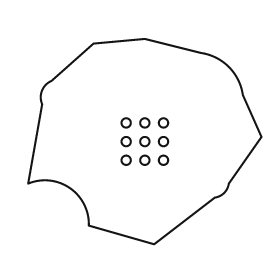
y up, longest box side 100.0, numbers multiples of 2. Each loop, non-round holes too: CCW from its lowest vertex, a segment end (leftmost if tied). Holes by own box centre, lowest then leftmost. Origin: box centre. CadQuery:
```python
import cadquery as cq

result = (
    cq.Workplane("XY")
    .moveTo(4.0, -44.0)
    .lineTo(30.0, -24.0)
    .threePointArc((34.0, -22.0), (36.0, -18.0))
    .lineTo(50.0, 2.0)
    .lineTo(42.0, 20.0)
    .threePointArc((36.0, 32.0), (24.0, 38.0))
    .lineTo(0.0, 44.0)
    .lineTo(-22.0, 42.0)
    .lineTo(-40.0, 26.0)
    .threePointArc((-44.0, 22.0), (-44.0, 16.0))
    .lineTo(-50.0, -18.0)
    .threePointArc((-32.0, -20.0), (-24.0, -36.0))
    .close()
    .moveTo(-8.0, -8.0)
    .circle(2.0)
    .moveTo(0.0, -8.0)
    .circle(2.0)
    .moveTo(8.0, -8.0)
    .circle(2.0)
    .moveTo(-8.0, 0.0)
    .circle(2.0)
    .moveTo(0.0, 0.0)
    .circle(2.0)
    .moveTo(8.0, 0.0)
    .circle(2.0)
    .moveTo(-8.0, 8.0)
    .circle(2.0)
    .moveTo(0.0, 8.0)
    .circle(2.0)
    .moveTo(8.0, 8.0)
    .circle(2.0)
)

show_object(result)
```